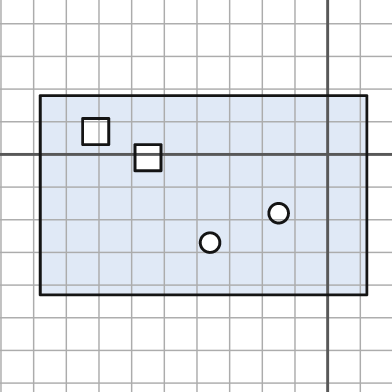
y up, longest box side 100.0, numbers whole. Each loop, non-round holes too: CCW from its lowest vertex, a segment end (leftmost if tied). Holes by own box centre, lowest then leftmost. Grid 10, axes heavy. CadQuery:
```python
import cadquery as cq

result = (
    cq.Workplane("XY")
    .moveTo(-88.0, -43.0)
    .lineTo(12.0, -43.0)
    .lineTo(12.0, 18.0)
    .lineTo(-88.0, 18.0)
    .close()
    .moveTo(-36.0, -27.0)
    .circle(3.0)
    .moveTo(-15.0, -18.0)
    .circle(3.0)
    .moveTo(-59.0, -5.0)
    .lineTo(-51.0, -5.0)
    .lineTo(-51.0, 3.0)
    .lineTo(-59.0, 3.0)
    .close()
    .moveTo(-75.0, 3.0)
    .lineTo(-67.0, 3.0)
    .lineTo(-67.0, 11.0)
    .lineTo(-75.0, 11.0)
    .close()
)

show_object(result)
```